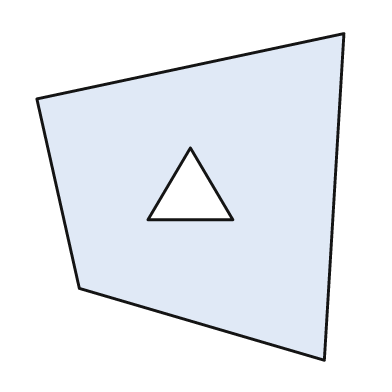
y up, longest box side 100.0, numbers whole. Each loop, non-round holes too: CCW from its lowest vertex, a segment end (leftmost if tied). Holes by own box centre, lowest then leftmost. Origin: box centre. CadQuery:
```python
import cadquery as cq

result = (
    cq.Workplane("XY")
    .moveTo(41.0, -50.0)
    .lineTo(47.0, 50.0)
    .lineTo(-47.0, 30.0)
    .lineTo(-34.0, -28.0)
    .close()
    .moveTo(-13.0, -7.0)
    .lineTo(13.0, -7.0)
    .lineTo(0.0, 15.0)
    .close()
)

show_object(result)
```